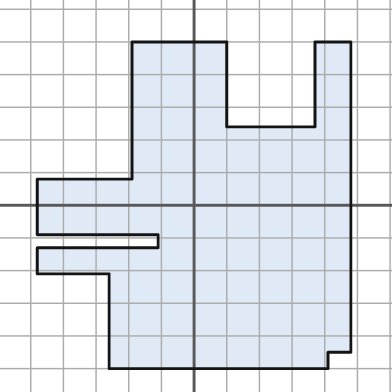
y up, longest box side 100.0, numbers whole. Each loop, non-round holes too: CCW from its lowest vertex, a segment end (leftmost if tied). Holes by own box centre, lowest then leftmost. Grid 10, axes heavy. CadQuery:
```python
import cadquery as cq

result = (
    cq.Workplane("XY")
    .moveTo(-26.0, -50.0)
    .lineTo(41.0, -50.0)
    .lineTo(41.0, -45.0)
    .lineTo(48.0, -45.0)
    .lineTo(48.0, 50.0)
    .lineTo(37.0, 50.0)
    .lineTo(37.0, 24.0)
    .lineTo(10.0, 24.0)
    .lineTo(10.0, 50.0)
    .lineTo(-19.0, 50.0)
    .lineTo(-19.0, 8.0)
    .lineTo(-48.0, 8.0)
    .lineTo(-48.0, -9.0)
    .lineTo(-11.0, -9.0)
    .lineTo(-11.0, -13.0)
    .lineTo(-48.0, -13.0)
    .lineTo(-48.0, -21.0)
    .lineTo(-26.0, -21.0)
    .close()
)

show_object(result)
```